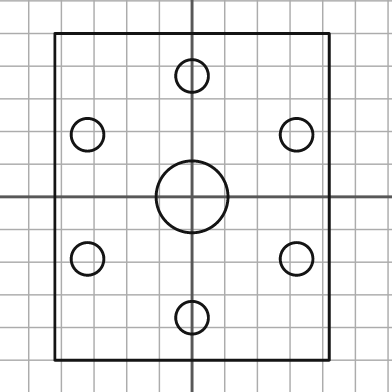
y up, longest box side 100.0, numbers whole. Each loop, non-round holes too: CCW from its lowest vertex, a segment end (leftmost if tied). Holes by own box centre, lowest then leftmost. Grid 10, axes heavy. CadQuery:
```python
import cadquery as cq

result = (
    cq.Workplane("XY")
    .moveTo(-42.0, -50.0)
    .lineTo(42.0, -50.0)
    .lineTo(42.0, 50.0)
    .lineTo(-42.0, 50.0)
    .close()
    .moveTo(0.0, -37.0)
    .circle(5.0)
    .moveTo(-32.0, -19.0)
    .circle(5.0)
    .moveTo(32.0, -19.0)
    .circle(5.0)
    .moveTo(0.0, 0.0)
    .circle(11.0)
    .moveTo(-32.0, 19.0)
    .circle(5.0)
    .moveTo(32.0, 19.0)
    .circle(5.0)
    .moveTo(0.0, 37.0)
    .circle(5.0)
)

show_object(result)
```